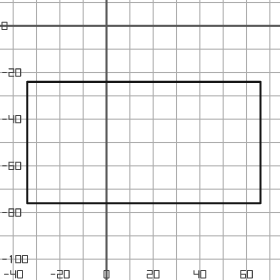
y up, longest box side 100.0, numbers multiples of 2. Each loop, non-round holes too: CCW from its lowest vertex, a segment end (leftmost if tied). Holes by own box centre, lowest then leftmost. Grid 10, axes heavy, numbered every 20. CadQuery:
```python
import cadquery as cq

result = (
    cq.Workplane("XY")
    .moveTo(-34.0, -76.0)
    .lineTo(66.0, -76.0)
    .lineTo(66.0, -24.0)
    .lineTo(-34.0, -24.0)
    .close()
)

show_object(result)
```